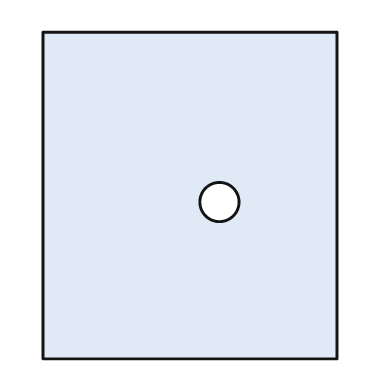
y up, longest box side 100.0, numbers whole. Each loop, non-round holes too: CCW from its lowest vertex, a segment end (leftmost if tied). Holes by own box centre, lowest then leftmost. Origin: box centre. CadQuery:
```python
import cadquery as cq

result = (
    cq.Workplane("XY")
    .moveTo(-45.0, -50.0)
    .lineTo(45.0, -50.0)
    .lineTo(45.0, 50.0)
    .lineTo(-45.0, 50.0)
    .close()
    .moveTo(9.0, -2.0)
    .circle(6.0)
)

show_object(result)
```